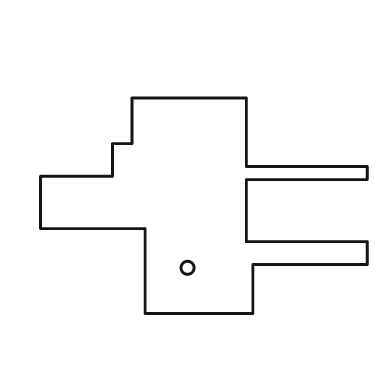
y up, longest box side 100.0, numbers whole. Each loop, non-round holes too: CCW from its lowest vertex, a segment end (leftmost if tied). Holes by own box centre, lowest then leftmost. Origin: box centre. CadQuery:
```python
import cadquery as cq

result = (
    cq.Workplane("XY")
    .moveTo(-18.0, -33.0)
    .lineTo(15.0, -33.0)
    .lineTo(15.0, -18.0)
    .lineTo(50.0, -18.0)
    .lineTo(50.0, -11.0)
    .lineTo(13.0, -11.0)
    .lineTo(13.0, 8.0)
    .lineTo(50.0, 8.0)
    .lineTo(50.0, 12.0)
    .lineTo(13.0, 12.0)
    .lineTo(13.0, 33.0)
    .lineTo(-22.0, 33.0)
    .lineTo(-22.0, 19.0)
    .lineTo(-28.0, 19.0)
    .lineTo(-28.0, 9.0)
    .lineTo(-50.0, 9.0)
    .lineTo(-50.0, -7.0)
    .lineTo(-18.0, -7.0)
    .close()
    .moveTo(-5.0, -19.0)
    .circle(2.0)
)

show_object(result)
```